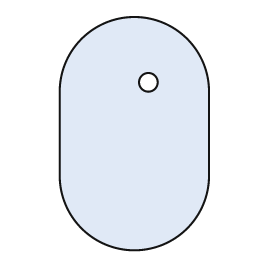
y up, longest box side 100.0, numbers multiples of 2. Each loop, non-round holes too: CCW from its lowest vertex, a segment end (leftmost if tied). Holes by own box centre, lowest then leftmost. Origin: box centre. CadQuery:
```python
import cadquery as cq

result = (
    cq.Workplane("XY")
    .moveTo(-32.0, -18.0)
    .threePointArc((0.0, -50.0), (32.0, -18.0))
    .lineTo(32.0, 18.0)
    .threePointArc((0.0, 50.0), (-32.0, 18.0))
    .close()
    .moveTo(6.0, 22.0)
    .circle(4.0)
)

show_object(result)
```